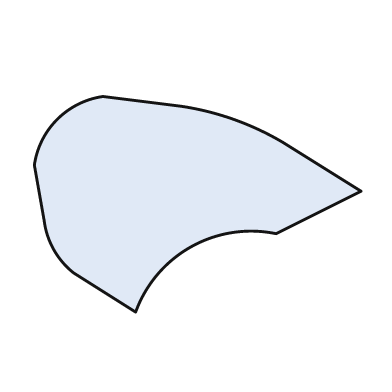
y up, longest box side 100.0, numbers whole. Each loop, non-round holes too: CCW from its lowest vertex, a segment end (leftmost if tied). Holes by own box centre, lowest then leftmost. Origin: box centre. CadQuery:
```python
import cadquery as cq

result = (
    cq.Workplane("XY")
    .moveTo(-19.0, -33.0)
    .threePointArc((-2.0, -13.0), (24.0, -9.0))
    .lineTo(50.0, 4.0)
    .lineTo(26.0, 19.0)
    .threePointArc((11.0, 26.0), (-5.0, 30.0))
    .lineTo(-29.0, 33.0)
    .threePointArc((-43.0, 26.0), (-50.0, 12.0))
    .lineTo(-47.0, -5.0)
    .threePointArc((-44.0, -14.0), (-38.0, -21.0))
    .close()
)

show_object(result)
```